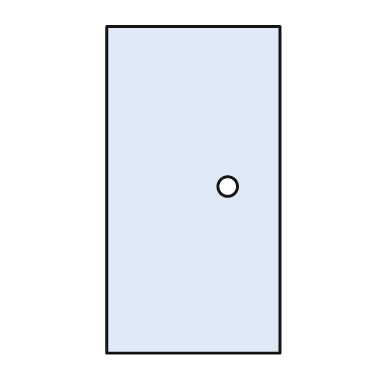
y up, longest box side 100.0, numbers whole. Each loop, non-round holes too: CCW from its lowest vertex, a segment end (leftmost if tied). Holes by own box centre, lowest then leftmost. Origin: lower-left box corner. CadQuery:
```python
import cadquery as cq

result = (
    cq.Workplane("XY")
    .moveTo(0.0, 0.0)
    .lineTo(53.0, 0.0)
    .lineTo(53.0, 100.0)
    .lineTo(0.0, 100.0)
    .close()
    .moveTo(37.0, 51.0)
    .circle(3.0)
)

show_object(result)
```